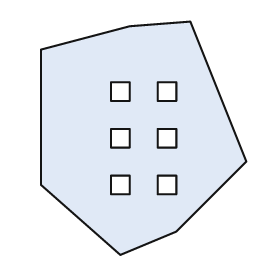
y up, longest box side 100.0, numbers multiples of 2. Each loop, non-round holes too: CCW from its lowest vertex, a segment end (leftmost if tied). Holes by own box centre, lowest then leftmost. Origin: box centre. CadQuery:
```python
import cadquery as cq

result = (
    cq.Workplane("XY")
    .moveTo(-10.0, -50.0)
    .lineTo(14.0, -40.0)
    .lineTo(44.0, -10.0)
    .lineTo(20.0, 50.0)
    .lineTo(-6.0, 48.0)
    .lineTo(-44.0, 38.0)
    .lineTo(-44.0, -20.0)
    .close()
    .moveTo(-14.0, -24.0)
    .lineTo(-6.0, -24.0)
    .lineTo(-6.0, -16.0)
    .lineTo(-14.0, -16.0)
    .close()
    .moveTo(6.0, -24.0)
    .lineTo(14.0, -24.0)
    .lineTo(14.0, -16.0)
    .lineTo(6.0, -16.0)
    .close()
    .moveTo(-14.0, -4.0)
    .lineTo(-6.0, -4.0)
    .lineTo(-6.0, 4.0)
    .lineTo(-14.0, 4.0)
    .close()
    .moveTo(6.0, -4.0)
    .lineTo(14.0, -4.0)
    .lineTo(14.0, 4.0)
    .lineTo(6.0, 4.0)
    .close()
    .moveTo(-14.0, 16.0)
    .lineTo(-6.0, 16.0)
    .lineTo(-6.0, 24.0)
    .lineTo(-14.0, 24.0)
    .close()
    .moveTo(6.0, 16.0)
    .lineTo(14.0, 16.0)
    .lineTo(14.0, 24.0)
    .lineTo(6.0, 24.0)
    .close()
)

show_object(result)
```